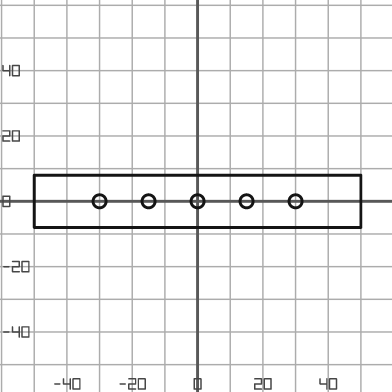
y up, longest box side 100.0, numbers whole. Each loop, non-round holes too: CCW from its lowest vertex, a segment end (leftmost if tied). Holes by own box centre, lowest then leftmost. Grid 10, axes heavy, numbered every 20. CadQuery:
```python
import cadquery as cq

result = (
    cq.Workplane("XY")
    .moveTo(-50.0, -8.0)
    .lineTo(50.0, -8.0)
    .lineTo(50.0, 8.0)
    .lineTo(-50.0, 8.0)
    .close()
    .moveTo(-30.0, 0.0)
    .circle(2.0)
    .moveTo(-15.0, 0.0)
    .circle(2.0)
    .moveTo(0.0, 0.0)
    .circle(2.0)
    .moveTo(15.0, 0.0)
    .circle(2.0)
    .moveTo(30.0, 0.0)
    .circle(2.0)
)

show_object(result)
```